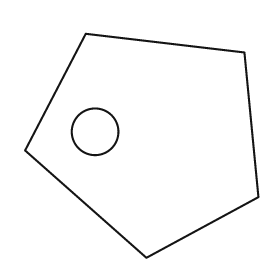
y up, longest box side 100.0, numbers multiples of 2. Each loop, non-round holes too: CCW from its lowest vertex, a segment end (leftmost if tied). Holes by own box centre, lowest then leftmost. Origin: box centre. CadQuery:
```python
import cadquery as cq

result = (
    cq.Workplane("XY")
    .moveTo(2.0, -48.0)
    .lineTo(50.0, -22.0)
    .lineTo(44.0, 40.0)
    .lineTo(-24.0, 48.0)
    .lineTo(-50.0, -2.0)
    .close()
    .moveTo(-20.0, 6.0)
    .circle(10.0)
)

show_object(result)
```